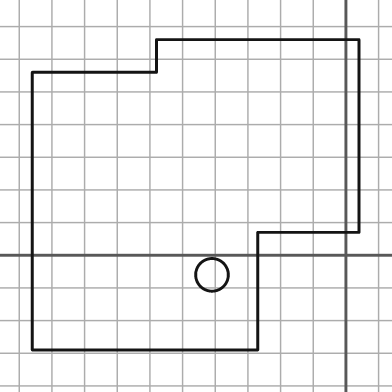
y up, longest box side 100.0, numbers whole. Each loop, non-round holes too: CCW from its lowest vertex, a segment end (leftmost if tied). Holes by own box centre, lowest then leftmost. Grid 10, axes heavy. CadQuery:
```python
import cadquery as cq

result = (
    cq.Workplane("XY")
    .moveTo(-96.0, -29.0)
    .lineTo(-27.0, -29.0)
    .lineTo(-27.0, 7.0)
    .lineTo(4.0, 7.0)
    .lineTo(4.0, 66.0)
    .lineTo(-58.0, 66.0)
    .lineTo(-58.0, 56.0)
    .lineTo(-96.0, 56.0)
    .close()
    .moveTo(-41.0, -6.0)
    .circle(5.0)
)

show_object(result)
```